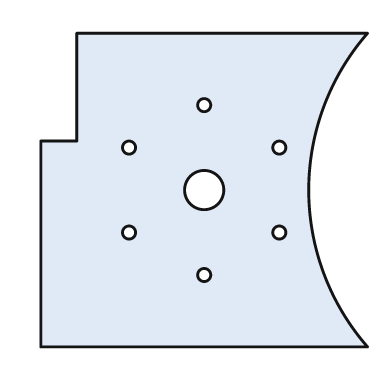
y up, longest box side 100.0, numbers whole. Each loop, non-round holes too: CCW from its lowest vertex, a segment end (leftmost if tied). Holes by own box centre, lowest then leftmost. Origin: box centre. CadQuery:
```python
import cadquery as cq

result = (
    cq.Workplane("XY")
    .moveTo(-50.0, -48.0)
    .lineTo(50.0, -48.0)
    .threePointArc((32.0, 0.0), (50.0, 48.0))
    .lineTo(-39.0, 48.0)
    .lineTo(-39.0, 15.0)
    .lineTo(-50.0, 15.0)
    .close()
    .moveTo(0.0, -26.0)
    .circle(2.0)
    .moveTo(-23.0, -13.0)
    .circle(2.0)
    .moveTo(23.0, -13.0)
    .circle(2.0)
    .moveTo(0.0, 0.0)
    .circle(6.0)
    .moveTo(-23.0, 13.0)
    .circle(2.0)
    .moveTo(23.0, 13.0)
    .circle(2.0)
    .moveTo(0.0, 26.0)
    .circle(2.0)
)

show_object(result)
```